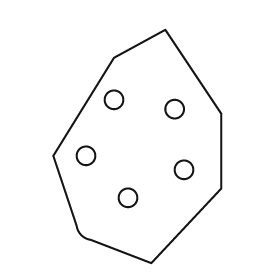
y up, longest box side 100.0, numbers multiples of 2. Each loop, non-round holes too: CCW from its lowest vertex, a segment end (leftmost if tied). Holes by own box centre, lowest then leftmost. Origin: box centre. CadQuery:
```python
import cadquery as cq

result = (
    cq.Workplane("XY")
    .moveTo(6.0, -50.0)
    .lineTo(36.0, -18.0)
    .lineTo(36.0, 14.0)
    .lineTo(12.0, 50.0)
    .lineTo(-10.0, 38.0)
    .lineTo(-36.0, -4.0)
    .lineTo(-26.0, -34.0)
    .threePointArc((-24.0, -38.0), (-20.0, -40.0))
    .close()
    .moveTo(-4.0, -22.0)
    .circle(4.0)
    .moveTo(20.0, -10.0)
    .circle(4.0)
    .moveTo(-22.0, -4.0)
    .circle(4.0)
    .moveTo(16.0, 16.0)
    .circle(4.0)
    .moveTo(-10.0, 20.0)
    .circle(4.0)
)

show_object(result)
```